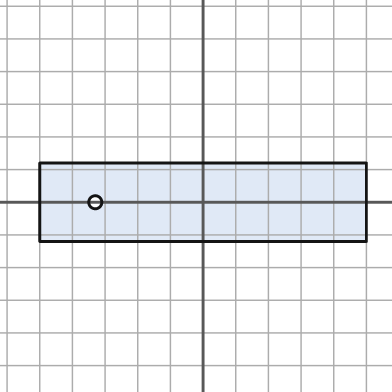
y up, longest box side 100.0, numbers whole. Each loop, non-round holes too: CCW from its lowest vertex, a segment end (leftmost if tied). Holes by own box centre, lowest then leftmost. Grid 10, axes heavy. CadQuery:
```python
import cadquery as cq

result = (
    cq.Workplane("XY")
    .moveTo(-50.0, -12.0)
    .lineTo(50.0, -12.0)
    .lineTo(50.0, 12.0)
    .lineTo(-50.0, 12.0)
    .close()
    .moveTo(-33.0, 0.0)
    .circle(2.0)
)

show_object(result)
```